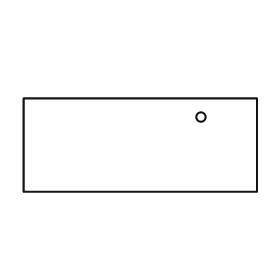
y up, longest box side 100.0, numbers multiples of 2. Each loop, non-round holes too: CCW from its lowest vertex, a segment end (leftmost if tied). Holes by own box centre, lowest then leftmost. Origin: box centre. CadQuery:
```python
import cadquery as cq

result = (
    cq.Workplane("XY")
    .moveTo(-50.0, -20.0)
    .lineTo(50.0, -20.0)
    .lineTo(50.0, 20.0)
    .lineTo(-50.0, 20.0)
    .close()
    .moveTo(26.0, 12.0)
    .circle(2.0)
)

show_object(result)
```